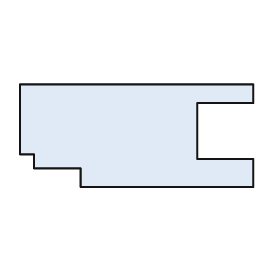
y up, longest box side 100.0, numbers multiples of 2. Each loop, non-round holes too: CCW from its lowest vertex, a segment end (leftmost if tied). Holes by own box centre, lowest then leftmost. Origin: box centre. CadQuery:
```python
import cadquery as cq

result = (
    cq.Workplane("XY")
    .moveTo(-24.0, -22.0)
    .lineTo(50.0, -22.0)
    .lineTo(50.0, -10.0)
    .lineTo(26.0, -10.0)
    .lineTo(26.0, 14.0)
    .lineTo(50.0, 14.0)
    .lineTo(50.0, 22.0)
    .lineTo(-50.0, 22.0)
    .lineTo(-50.0, -8.0)
    .lineTo(-44.0, -8.0)
    .lineTo(-44.0, -14.0)
    .lineTo(-24.0, -14.0)
    .close()
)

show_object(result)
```